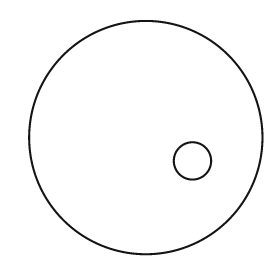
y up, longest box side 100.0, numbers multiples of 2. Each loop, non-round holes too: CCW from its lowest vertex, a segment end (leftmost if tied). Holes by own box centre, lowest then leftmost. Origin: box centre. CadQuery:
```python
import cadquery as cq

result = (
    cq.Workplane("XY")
    .moveTo(0.0, 0.0)
    .circle(50.0)
    .moveTo(20.0, -10.0)
    .circle(8.0)
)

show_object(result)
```